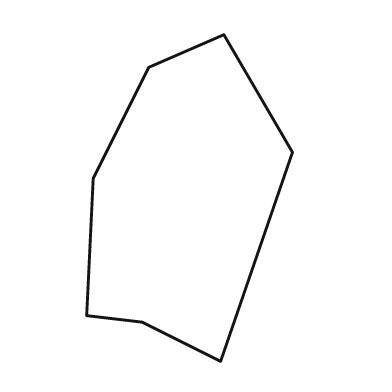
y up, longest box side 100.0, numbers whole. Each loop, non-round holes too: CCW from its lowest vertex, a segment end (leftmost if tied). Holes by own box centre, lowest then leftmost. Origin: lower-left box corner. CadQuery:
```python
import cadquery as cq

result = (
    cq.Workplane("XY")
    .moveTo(41.0, 0.0)
    .lineTo(63.0, 64.0)
    .lineTo(42.0, 100.0)
    .lineTo(19.0, 90.0)
    .lineTo(2.0, 56.0)
    .lineTo(0.0, 14.0)
    .lineTo(17.0, 12.0)
    .close()
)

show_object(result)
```